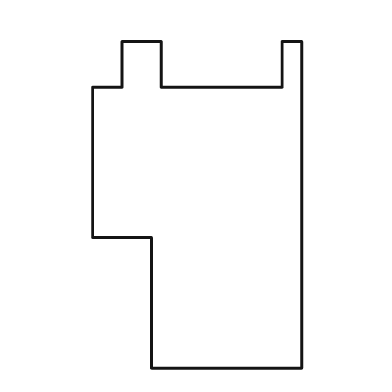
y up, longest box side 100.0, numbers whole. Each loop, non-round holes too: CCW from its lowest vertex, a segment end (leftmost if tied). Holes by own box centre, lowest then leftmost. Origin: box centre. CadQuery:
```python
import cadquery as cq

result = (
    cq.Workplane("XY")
    .moveTo(-14.0, -50.0)
    .lineTo(32.0, -50.0)
    .lineTo(32.0, 50.0)
    .lineTo(26.0, 50.0)
    .lineTo(26.0, 36.0)
    .lineTo(-11.0, 36.0)
    .lineTo(-11.0, 50.0)
    .lineTo(-23.0, 50.0)
    .lineTo(-23.0, 36.0)
    .lineTo(-32.0, 36.0)
    .lineTo(-32.0, -10.0)
    .lineTo(-14.0, -10.0)
    .close()
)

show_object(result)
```